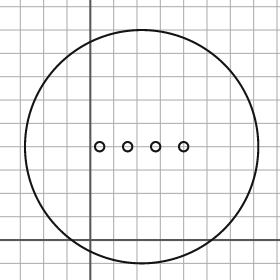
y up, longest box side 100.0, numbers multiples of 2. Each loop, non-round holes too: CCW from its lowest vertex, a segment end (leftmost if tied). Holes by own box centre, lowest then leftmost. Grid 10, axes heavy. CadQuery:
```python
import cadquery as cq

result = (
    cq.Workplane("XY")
    .moveTo(22.0, 40.0)
    .circle(50.0)
    .moveTo(4.0, 40.0)
    .circle(2.0)
    .moveTo(16.0, 40.0)
    .circle(2.0)
    .moveTo(28.0, 40.0)
    .circle(2.0)
    .moveTo(40.0, 40.0)
    .circle(2.0)
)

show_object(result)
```